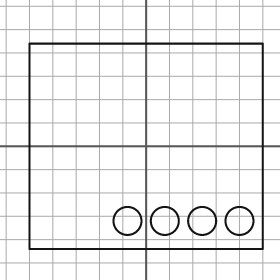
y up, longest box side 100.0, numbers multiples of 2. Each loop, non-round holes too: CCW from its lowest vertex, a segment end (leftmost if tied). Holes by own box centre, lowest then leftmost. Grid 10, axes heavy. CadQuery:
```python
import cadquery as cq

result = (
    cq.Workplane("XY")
    .moveTo(-50.0, -44.0)
    .lineTo(50.0, -44.0)
    .lineTo(50.0, 44.0)
    .lineTo(-50.0, 44.0)
    .close()
    .moveTo(-8.0, -32.0)
    .circle(6.0)
    .moveTo(8.0, -32.0)
    .circle(6.0)
    .moveTo(24.0, -32.0)
    .circle(6.0)
    .moveTo(40.0, -32.0)
    .circle(6.0)
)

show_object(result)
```